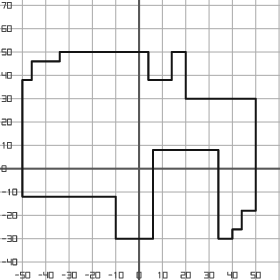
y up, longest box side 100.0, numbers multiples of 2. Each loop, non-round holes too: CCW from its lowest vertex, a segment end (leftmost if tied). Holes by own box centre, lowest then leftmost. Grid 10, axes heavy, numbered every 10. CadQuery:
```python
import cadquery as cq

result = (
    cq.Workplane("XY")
    .moveTo(-10.0, -30.0)
    .lineTo(6.0, -30.0)
    .lineTo(6.0, 8.0)
    .lineTo(34.0, 8.0)
    .lineTo(34.0, -30.0)
    .lineTo(40.0, -30.0)
    .lineTo(40.0, -26.0)
    .lineTo(44.0, -26.0)
    .lineTo(44.0, -18.0)
    .lineTo(50.0, -18.0)
    .lineTo(50.0, 30.0)
    .lineTo(20.0, 30.0)
    .lineTo(20.0, 50.0)
    .lineTo(14.0, 50.0)
    .lineTo(14.0, 38.0)
    .lineTo(4.0, 38.0)
    .lineTo(4.0, 50.0)
    .lineTo(-34.0, 50.0)
    .lineTo(-34.0, 46.0)
    .lineTo(-46.0, 46.0)
    .lineTo(-46.0, 38.0)
    .lineTo(-50.0, 38.0)
    .lineTo(-50.0, -12.0)
    .lineTo(-10.0, -12.0)
    .close()
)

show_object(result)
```